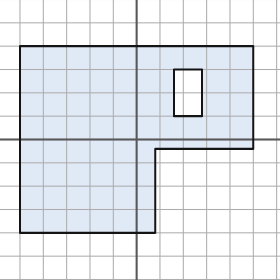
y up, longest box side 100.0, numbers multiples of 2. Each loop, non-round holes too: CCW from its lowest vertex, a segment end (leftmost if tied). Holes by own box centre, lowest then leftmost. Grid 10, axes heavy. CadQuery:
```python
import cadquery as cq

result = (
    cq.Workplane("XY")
    .moveTo(-50.0, -40.0)
    .lineTo(8.0, -40.0)
    .lineTo(8.0, -4.0)
    .lineTo(50.0, -4.0)
    .lineTo(50.0, 40.0)
    .lineTo(-50.0, 40.0)
    .close()
    .moveTo(16.0, 10.0)
    .lineTo(28.0, 10.0)
    .lineTo(28.0, 30.0)
    .lineTo(16.0, 30.0)
    .close()
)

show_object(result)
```